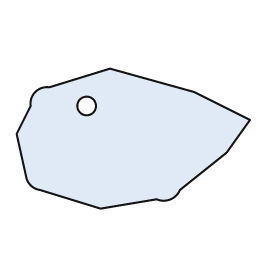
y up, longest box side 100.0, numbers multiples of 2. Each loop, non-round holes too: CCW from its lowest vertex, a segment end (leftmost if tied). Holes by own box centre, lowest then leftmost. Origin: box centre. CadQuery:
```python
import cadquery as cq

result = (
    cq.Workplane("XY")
    .moveTo(-14.0, -30.0)
    .lineTo(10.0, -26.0)
    .threePointArc((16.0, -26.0), (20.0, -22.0))
    .lineTo(40.0, -6.0)
    .lineTo(50.0, 8.0)
    .lineTo(26.0, 20.0)
    .lineTo(-10.0, 30.0)
    .lineTo(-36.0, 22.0)
    .threePointArc((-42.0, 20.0), (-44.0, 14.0))
    .lineTo(-50.0, 2.0)
    .lineTo(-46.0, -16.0)
    .threePointArc((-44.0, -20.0), (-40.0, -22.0))
    .close()
    .moveTo(-20.0, 14.0)
    .circle(4.0)
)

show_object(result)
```